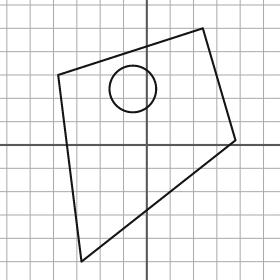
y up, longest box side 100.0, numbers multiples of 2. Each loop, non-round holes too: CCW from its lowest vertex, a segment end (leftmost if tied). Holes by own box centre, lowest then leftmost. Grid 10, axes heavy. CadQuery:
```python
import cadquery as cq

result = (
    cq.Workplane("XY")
    .moveTo(-28.0, -50.0)
    .lineTo(38.0, 2.0)
    .lineTo(24.0, 50.0)
    .lineTo(-38.0, 30.0)
    .close()
    .moveTo(-6.0, 24.0)
    .circle(10.0)
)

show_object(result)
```